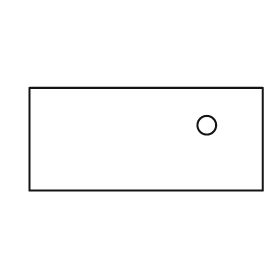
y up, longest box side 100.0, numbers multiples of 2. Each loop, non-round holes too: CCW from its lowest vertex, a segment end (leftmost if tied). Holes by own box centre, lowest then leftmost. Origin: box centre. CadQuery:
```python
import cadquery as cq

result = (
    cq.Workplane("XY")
    .moveTo(-50.0, -22.0)
    .lineTo(50.0, -22.0)
    .lineTo(50.0, 22.0)
    .lineTo(-50.0, 22.0)
    .close()
    .moveTo(26.0, 6.0)
    .circle(4.0)
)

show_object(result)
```